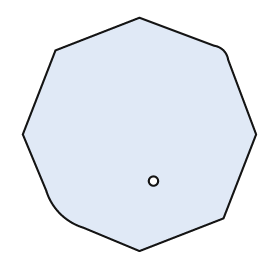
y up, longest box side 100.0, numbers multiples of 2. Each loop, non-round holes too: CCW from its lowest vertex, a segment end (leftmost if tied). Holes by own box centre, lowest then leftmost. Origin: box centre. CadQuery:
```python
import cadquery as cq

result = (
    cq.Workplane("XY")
    .moveTo(0.0, -50.0)
    .lineTo(36.0, -36.0)
    .lineTo(50.0, 0.0)
    .lineTo(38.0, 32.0)
    .threePointArc((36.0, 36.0), (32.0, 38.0))
    .lineTo(0.0, 50.0)
    .lineTo(-36.0, 36.0)
    .lineTo(-50.0, 0.0)
    .lineTo(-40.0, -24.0)
    .threePointArc((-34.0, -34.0), (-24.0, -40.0))
    .close()
    .moveTo(6.0, -20.0)
    .circle(2.0)
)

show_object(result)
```